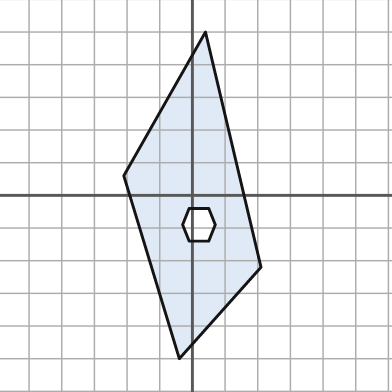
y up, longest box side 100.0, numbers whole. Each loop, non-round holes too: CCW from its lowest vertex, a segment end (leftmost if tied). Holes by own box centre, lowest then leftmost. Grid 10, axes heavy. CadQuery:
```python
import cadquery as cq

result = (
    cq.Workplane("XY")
    .moveTo(-4.0, -50.0)
    .lineTo(21.0, -22.0)
    .lineTo(4.0, 50.0)
    .lineTo(-21.0, 6.0)
    .close()
    .moveTo(-1.0, -14.0)
    .lineTo(5.0, -14.0)
    .lineTo(7.0, -9.0)
    .lineTo(5.0, -4.0)
    .lineTo(-1.0, -4.0)
    .lineTo(-3.0, -9.0)
    .close()
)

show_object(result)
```